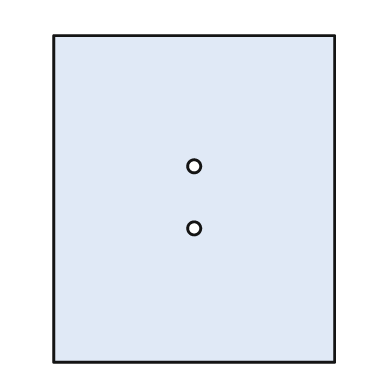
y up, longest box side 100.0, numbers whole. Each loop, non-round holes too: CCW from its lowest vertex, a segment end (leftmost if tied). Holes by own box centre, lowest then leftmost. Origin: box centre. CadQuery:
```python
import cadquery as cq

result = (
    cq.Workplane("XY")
    .moveTo(-43.0, -50.0)
    .lineTo(43.0, -50.0)
    .lineTo(43.0, 50.0)
    .lineTo(-43.0, 50.0)
    .close()
    .moveTo(0.0, -9.0)
    .circle(2.0)
    .moveTo(0.0, 10.0)
    .circle(2.0)
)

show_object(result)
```